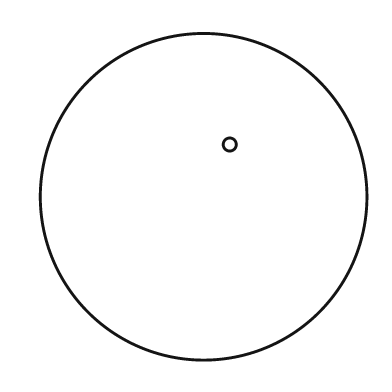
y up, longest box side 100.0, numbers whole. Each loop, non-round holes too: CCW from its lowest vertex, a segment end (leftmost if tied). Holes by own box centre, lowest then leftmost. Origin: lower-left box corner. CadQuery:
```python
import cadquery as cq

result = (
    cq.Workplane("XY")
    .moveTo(50.0, 50.0)
    .circle(50.0)
    .moveTo(58.0, 66.0)
    .circle(2.0)
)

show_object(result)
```